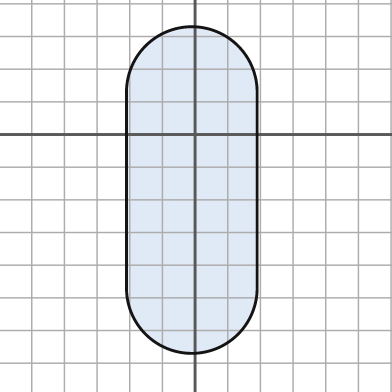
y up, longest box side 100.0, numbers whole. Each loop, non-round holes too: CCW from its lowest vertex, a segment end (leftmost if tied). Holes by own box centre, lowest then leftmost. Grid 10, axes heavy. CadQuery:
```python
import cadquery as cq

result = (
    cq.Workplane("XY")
    .moveTo(-21.0, -47.0)
    .threePointArc((-1.0, -67.0), (19.0, -47.0))
    .lineTo(19.0, 13.0)
    .threePointArc((-1.0, 33.0), (-21.0, 13.0))
    .close()
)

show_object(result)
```